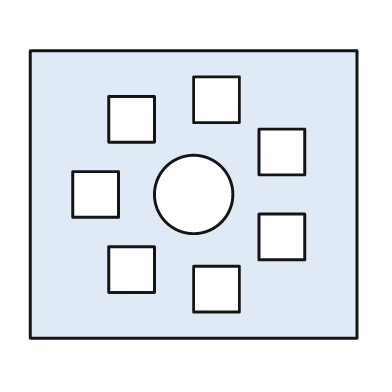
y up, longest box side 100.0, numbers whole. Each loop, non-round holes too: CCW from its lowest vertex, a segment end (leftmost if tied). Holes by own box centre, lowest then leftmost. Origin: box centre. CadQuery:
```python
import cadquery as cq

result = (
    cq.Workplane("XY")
    .moveTo(-50.0, -44.0)
    .lineTo(50.0, -44.0)
    .lineTo(50.0, 44.0)
    .lineTo(-50.0, 44.0)
    .close()
    .moveTo(0.0, -36.0)
    .lineTo(14.0, -36.0)
    .lineTo(14.0, -22.0)
    .lineTo(0.0, -22.0)
    .close()
    .moveTo(-26.0, -30.0)
    .lineTo(-12.0, -30.0)
    .lineTo(-12.0, -16.0)
    .lineTo(-26.0, -16.0)
    .close()
    .moveTo(20.0, -20.0)
    .lineTo(34.0, -20.0)
    .lineTo(34.0, -6.0)
    .lineTo(20.0, -6.0)
    .close()
    .moveTo(-37.0, -7.0)
    .lineTo(-23.0, -7.0)
    .lineTo(-23.0, 7.0)
    .lineTo(-37.0, 7.0)
    .close()
    .moveTo(0.0, 0.0)
    .circle(12.0)
    .moveTo(20.0, 6.0)
    .lineTo(34.0, 6.0)
    .lineTo(34.0, 20.0)
    .lineTo(20.0, 20.0)
    .close()
    .moveTo(-26.0, 16.0)
    .lineTo(-12.0, 16.0)
    .lineTo(-12.0, 30.0)
    .lineTo(-26.0, 30.0)
    .close()
    .moveTo(0.0, 22.0)
    .lineTo(14.0, 22.0)
    .lineTo(14.0, 36.0)
    .lineTo(0.0, 36.0)
    .close()
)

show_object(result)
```